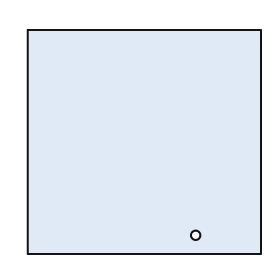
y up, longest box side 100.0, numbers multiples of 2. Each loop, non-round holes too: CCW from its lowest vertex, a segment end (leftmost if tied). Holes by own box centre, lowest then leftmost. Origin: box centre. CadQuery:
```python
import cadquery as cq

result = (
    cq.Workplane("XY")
    .moveTo(-50.0, -48.0)
    .lineTo(50.0, -48.0)
    .lineTo(50.0, 48.0)
    .lineTo(-50.0, 48.0)
    .close()
    .moveTo(22.0, -40.0)
    .circle(2.0)
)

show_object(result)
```